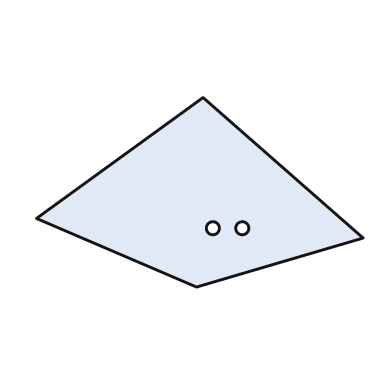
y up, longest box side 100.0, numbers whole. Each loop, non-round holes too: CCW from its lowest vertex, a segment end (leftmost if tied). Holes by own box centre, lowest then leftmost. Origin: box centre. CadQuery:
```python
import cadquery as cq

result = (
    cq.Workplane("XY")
    .moveTo(-1.0, -29.0)
    .lineTo(50.0, -14.0)
    .lineTo(1.0, 29.0)
    .lineTo(-50.0, -8.0)
    .close()
    .moveTo(4.0, -11.0)
    .circle(2.0)
    .moveTo(13.0, -11.0)
    .circle(2.0)
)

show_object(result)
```